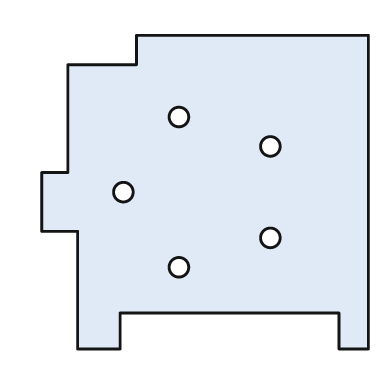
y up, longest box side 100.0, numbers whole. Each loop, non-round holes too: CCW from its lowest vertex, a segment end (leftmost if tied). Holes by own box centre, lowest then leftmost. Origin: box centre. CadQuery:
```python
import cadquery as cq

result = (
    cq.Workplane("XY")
    .moveTo(-39.0, -48.0)
    .lineTo(-26.0, -48.0)
    .lineTo(-26.0, -37.0)
    .lineTo(41.0, -37.0)
    .lineTo(41.0, -48.0)
    .lineTo(50.0, -48.0)
    .lineTo(50.0, 48.0)
    .lineTo(-21.0, 48.0)
    .lineTo(-21.0, 39.0)
    .lineTo(-42.0, 39.0)
    .lineTo(-42.0, 6.0)
    .lineTo(-50.0, 6.0)
    .lineTo(-50.0, -12.0)
    .lineTo(-39.0, -12.0)
    .close()
    .moveTo(-8.0, -23.0)
    .circle(3.0)
    .moveTo(20.0, -14.0)
    .circle(3.0)
    .moveTo(-25.0, 0.0)
    .circle(3.0)
    .moveTo(20.0, 14.0)
    .circle(3.0)
    .moveTo(-8.0, 23.0)
    .circle(3.0)
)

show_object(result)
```